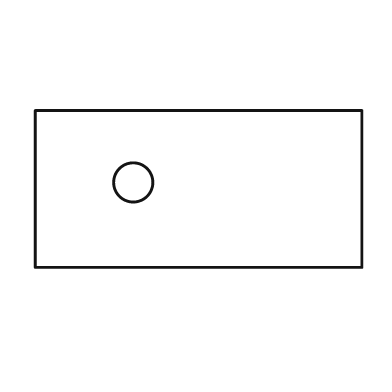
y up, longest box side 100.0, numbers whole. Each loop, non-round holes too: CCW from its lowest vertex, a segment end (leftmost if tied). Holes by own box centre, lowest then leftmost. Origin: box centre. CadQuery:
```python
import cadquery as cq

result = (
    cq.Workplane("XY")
    .moveTo(-50.0, -24.0)
    .lineTo(50.0, -24.0)
    .lineTo(50.0, 24.0)
    .lineTo(-50.0, 24.0)
    .close()
    .moveTo(-20.0, 2.0)
    .circle(6.0)
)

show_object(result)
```